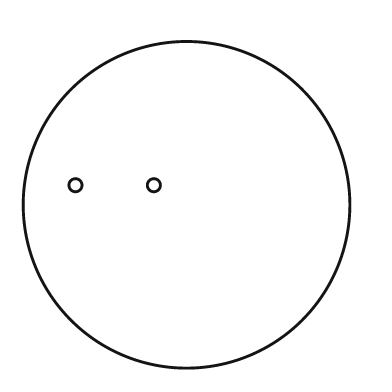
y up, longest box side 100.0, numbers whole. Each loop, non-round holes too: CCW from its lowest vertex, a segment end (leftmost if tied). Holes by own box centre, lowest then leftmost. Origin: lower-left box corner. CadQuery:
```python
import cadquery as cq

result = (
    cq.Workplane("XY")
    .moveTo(50.0, 50.0)
    .circle(50.0)
    .moveTo(16.0, 56.0)
    .circle(2.0)
    .moveTo(40.0, 56.0)
    .circle(2.0)
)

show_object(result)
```